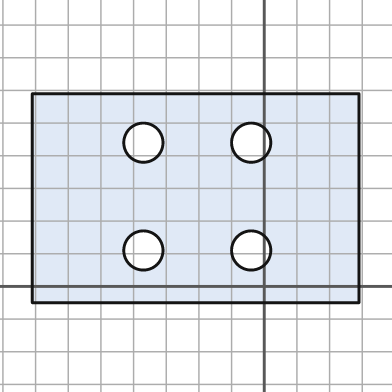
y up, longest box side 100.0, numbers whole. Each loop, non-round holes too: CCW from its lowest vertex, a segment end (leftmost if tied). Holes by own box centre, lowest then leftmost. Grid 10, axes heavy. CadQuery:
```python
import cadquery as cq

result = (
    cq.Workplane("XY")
    .moveTo(-71.0, -5.0)
    .lineTo(29.0, -5.0)
    .lineTo(29.0, 59.0)
    .lineTo(-71.0, 59.0)
    .close()
    .moveTo(-37.0, 11.0)
    .circle(6.0)
    .moveTo(-4.0, 11.0)
    .circle(6.0)
    .moveTo(-37.0, 44.0)
    .circle(6.0)
    .moveTo(-4.0, 44.0)
    .circle(6.0)
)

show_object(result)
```